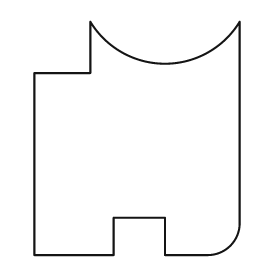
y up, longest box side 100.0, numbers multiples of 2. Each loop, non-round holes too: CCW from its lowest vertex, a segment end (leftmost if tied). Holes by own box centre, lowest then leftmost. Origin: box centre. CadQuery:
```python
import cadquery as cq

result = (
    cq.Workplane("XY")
    .moveTo(-44.0, -50.0)
    .lineTo(-10.0, -50.0)
    .lineTo(-10.0, -34.0)
    .lineTo(12.0, -34.0)
    .lineTo(12.0, -50.0)
    .lineTo(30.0, -50.0)
    .threePointArc((40.0, -46.0), (44.0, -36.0))
    .lineTo(44.0, 50.0)
    .threePointArc((12.0, 32.0), (-20.0, 50.0))
    .lineTo(-20.0, 28.0)
    .lineTo(-44.0, 28.0)
    .close()
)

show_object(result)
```